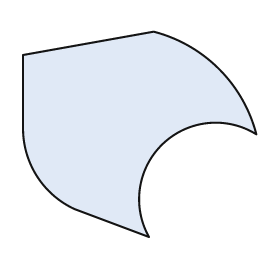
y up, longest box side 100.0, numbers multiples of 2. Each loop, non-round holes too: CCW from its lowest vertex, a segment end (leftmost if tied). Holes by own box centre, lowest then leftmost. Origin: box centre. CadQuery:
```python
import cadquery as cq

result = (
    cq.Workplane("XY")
    .moveTo(4.0, -44.0)
    .threePointArc((10.0, -4.0), (50.0, 0.0))
    .threePointArc((34.0, 28.0), (6.0, 44.0))
    .lineTo(-50.0, 34.0)
    .lineTo(-50.0, 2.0)
    .threePointArc((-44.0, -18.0), (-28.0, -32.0))
    .close()
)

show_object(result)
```